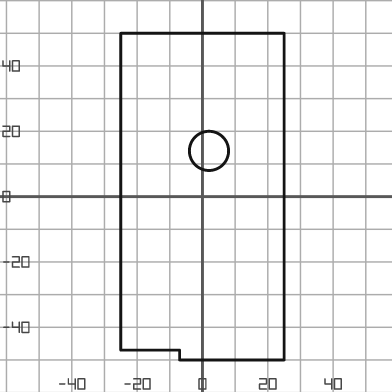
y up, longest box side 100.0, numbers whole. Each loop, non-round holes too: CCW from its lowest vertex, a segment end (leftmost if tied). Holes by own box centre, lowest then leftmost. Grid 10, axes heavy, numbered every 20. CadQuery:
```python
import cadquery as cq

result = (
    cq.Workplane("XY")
    .moveTo(-7.0, -50.0)
    .lineTo(25.0, -50.0)
    .lineTo(25.0, 50.0)
    .lineTo(-25.0, 50.0)
    .lineTo(-25.0, -47.0)
    .lineTo(-7.0, -47.0)
    .close()
    .moveTo(2.0, 14.0)
    .circle(6.0)
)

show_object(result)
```